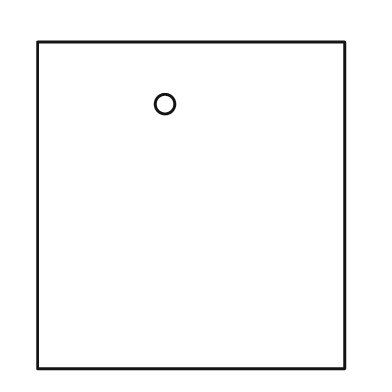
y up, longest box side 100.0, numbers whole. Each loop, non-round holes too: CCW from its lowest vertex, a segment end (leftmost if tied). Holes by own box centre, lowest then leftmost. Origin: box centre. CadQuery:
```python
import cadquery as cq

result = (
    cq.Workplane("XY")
    .moveTo(-47.0, -50.0)
    .lineTo(47.0, -50.0)
    .lineTo(47.0, 50.0)
    .lineTo(-47.0, 50.0)
    .close()
    .moveTo(-8.0, 31.0)
    .circle(3.0)
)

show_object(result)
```